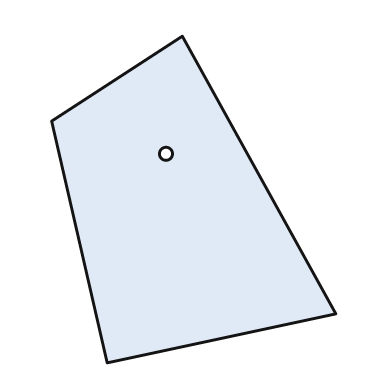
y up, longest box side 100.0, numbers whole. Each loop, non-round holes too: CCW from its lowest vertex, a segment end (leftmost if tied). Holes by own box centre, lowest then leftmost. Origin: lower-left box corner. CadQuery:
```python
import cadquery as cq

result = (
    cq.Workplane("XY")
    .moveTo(17.0, 0.0)
    .lineTo(87.0, 15.0)
    .lineTo(40.0, 100.0)
    .lineTo(0.0, 74.0)
    .close()
    .moveTo(35.0, 64.0)
    .circle(2.0)
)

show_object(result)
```